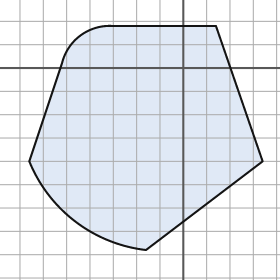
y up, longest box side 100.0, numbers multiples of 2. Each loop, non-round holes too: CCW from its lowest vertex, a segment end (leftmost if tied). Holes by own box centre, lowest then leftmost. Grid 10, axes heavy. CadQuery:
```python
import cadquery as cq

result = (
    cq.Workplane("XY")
    .moveTo(-16.0, -78.0)
    .lineTo(34.0, -40.0)
    .lineTo(14.0, 18.0)
    .lineTo(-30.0, 18.0)
    .threePointArc((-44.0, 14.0), (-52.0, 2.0))
    .lineTo(-66.0, -40.0)
    .threePointArc((-46.0, -66.0), (-16.0, -78.0))
    .close()
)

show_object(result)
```